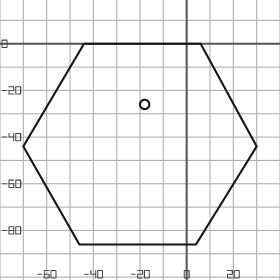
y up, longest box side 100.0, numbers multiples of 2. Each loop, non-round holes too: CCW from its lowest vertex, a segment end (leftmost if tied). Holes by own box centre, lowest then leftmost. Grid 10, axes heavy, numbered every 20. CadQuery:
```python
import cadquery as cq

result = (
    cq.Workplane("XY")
    .moveTo(-46.0, -86.0)
    .lineTo(4.0, -86.0)
    .lineTo(30.0, -44.0)
    .lineTo(6.0, 0.0)
    .lineTo(-44.0, 0.0)
    .lineTo(-70.0, -44.0)
    .close()
    .moveTo(-18.0, -26.0)
    .circle(2.0)
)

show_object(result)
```